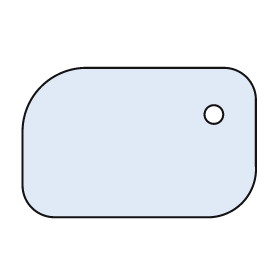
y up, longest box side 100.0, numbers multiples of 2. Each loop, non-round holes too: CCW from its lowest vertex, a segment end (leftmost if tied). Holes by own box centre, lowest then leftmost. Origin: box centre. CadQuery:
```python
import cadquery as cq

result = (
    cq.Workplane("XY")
    .moveTo(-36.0, -32.0)
    .lineTo(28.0, -32.0)
    .threePointArc((44.0, -26.0), (50.0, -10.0))
    .lineTo(50.0, 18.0)
    .threePointArc((46.0, 28.0), (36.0, 32.0))
    .lineTo(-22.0, 32.0)
    .threePointArc((-42.0, 24.0), (-50.0, 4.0))
    .lineTo(-50.0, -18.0)
    .threePointArc((-46.0, -28.0), (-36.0, -32.0))
    .close()
    .moveTo(32.0, 12.0)
    .circle(4.0)
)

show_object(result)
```